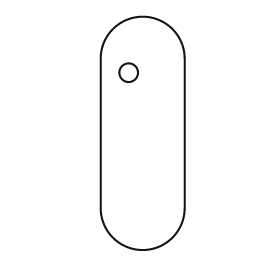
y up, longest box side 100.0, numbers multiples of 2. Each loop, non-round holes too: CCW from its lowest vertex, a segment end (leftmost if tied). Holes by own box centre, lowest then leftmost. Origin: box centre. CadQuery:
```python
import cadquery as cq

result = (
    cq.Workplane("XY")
    .moveTo(-18.0, -32.0)
    .threePointArc((0.0, -50.0), (18.0, -32.0))
    .lineTo(18.0, 32.0)
    .threePointArc((0.0, 50.0), (-18.0, 32.0))
    .close()
    .moveTo(-6.0, 26.0)
    .circle(4.0)
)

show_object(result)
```